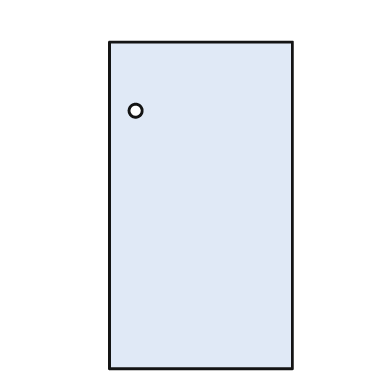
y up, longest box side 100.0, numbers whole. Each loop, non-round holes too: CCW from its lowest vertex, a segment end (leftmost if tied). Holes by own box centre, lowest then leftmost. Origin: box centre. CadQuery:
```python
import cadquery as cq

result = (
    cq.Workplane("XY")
    .moveTo(-28.0, -50.0)
    .lineTo(28.0, -50.0)
    .lineTo(28.0, 50.0)
    .lineTo(-28.0, 50.0)
    .close()
    .moveTo(-20.0, 29.0)
    .circle(2.0)
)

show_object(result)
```